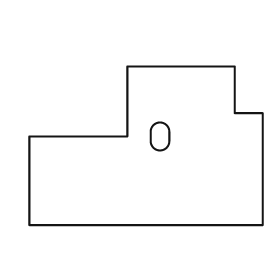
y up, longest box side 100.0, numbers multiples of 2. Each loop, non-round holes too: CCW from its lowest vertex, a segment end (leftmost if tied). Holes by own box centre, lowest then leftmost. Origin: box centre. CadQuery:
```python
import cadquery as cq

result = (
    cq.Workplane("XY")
    .moveTo(-50.0, -34.0)
    .lineTo(50.0, -34.0)
    .lineTo(50.0, 14.0)
    .lineTo(38.0, 14.0)
    .lineTo(38.0, 34.0)
    .lineTo(-8.0, 34.0)
    .lineTo(-8.0, 4.0)
    .lineTo(-50.0, 4.0)
    .close()
    .moveTo(2.0, 2.0)
    .threePointArc((6.0, -2.0), (10.0, 2.0))
    .lineTo(10.0, 6.0)
    .threePointArc((6.0, 10.0), (2.0, 6.0))
    .close()
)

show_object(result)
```